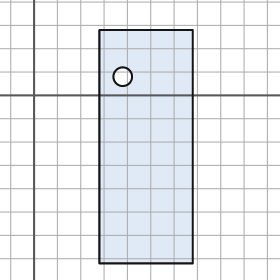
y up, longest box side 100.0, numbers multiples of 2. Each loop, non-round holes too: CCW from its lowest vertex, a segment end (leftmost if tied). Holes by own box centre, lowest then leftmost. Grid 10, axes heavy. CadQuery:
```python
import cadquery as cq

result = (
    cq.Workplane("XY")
    .moveTo(28.0, -72.0)
    .lineTo(68.0, -72.0)
    .lineTo(68.0, 28.0)
    .lineTo(28.0, 28.0)
    .close()
    .moveTo(38.0, 8.0)
    .circle(4.0)
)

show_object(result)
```